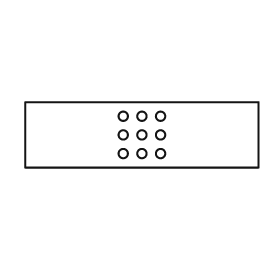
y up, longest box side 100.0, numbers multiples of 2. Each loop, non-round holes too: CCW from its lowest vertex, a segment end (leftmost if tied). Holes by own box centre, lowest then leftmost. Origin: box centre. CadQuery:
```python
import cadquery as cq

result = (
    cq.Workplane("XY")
    .moveTo(-50.0, -14.0)
    .lineTo(50.0, -14.0)
    .lineTo(50.0, 14.0)
    .lineTo(-50.0, 14.0)
    .close()
    .moveTo(-8.0, -8.0)
    .circle(2.0)
    .moveTo(0.0, -8.0)
    .circle(2.0)
    .moveTo(8.0, -8.0)
    .circle(2.0)
    .moveTo(-8.0, 0.0)
    .circle(2.0)
    .moveTo(0.0, 0.0)
    .circle(2.0)
    .moveTo(8.0, 0.0)
    .circle(2.0)
    .moveTo(-8.0, 8.0)
    .circle(2.0)
    .moveTo(0.0, 8.0)
    .circle(2.0)
    .moveTo(8.0, 8.0)
    .circle(2.0)
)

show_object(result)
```